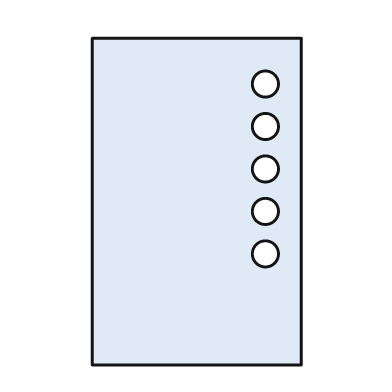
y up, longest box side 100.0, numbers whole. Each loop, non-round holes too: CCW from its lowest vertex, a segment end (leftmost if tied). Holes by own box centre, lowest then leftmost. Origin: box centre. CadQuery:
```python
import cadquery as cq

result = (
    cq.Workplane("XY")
    .moveTo(-32.0, -50.0)
    .lineTo(32.0, -50.0)
    .lineTo(32.0, 50.0)
    .lineTo(-32.0, 50.0)
    .close()
    .moveTo(21.0, -16.0)
    .circle(4.0)
    .moveTo(21.0, -3.0)
    .circle(4.0)
    .moveTo(21.0, 10.0)
    .circle(4.0)
    .moveTo(21.0, 23.0)
    .circle(4.0)
    .moveTo(21.0, 36.0)
    .circle(4.0)
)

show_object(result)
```